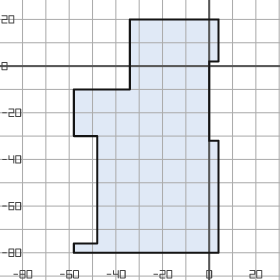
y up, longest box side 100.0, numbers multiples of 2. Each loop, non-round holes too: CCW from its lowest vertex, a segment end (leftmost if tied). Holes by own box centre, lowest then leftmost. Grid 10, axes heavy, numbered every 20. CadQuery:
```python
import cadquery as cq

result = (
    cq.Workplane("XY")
    .moveTo(-58.0, -80.0)
    .lineTo(4.0, -80.0)
    .lineTo(4.0, -32.0)
    .lineTo(0.0, -32.0)
    .lineTo(0.0, 2.0)
    .lineTo(4.0, 2.0)
    .lineTo(4.0, 20.0)
    .lineTo(-34.0, 20.0)
    .lineTo(-34.0, -10.0)
    .lineTo(-58.0, -10.0)
    .lineTo(-58.0, -30.0)
    .lineTo(-48.0, -30.0)
    .lineTo(-48.0, -76.0)
    .lineTo(-58.0, -76.0)
    .close()
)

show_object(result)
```